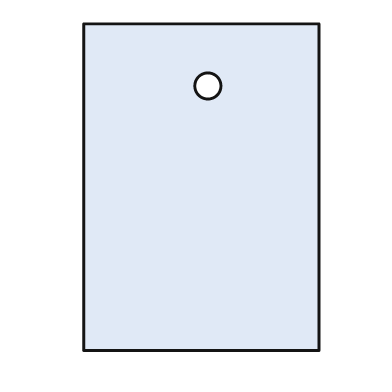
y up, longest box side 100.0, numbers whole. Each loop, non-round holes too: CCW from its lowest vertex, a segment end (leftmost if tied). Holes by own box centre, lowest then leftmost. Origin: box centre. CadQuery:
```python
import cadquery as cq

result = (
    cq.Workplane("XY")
    .moveTo(-36.0, -50.0)
    .lineTo(36.0, -50.0)
    .lineTo(36.0, 50.0)
    .lineTo(-36.0, 50.0)
    .close()
    .moveTo(2.0, 31.0)
    .circle(4.0)
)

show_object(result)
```